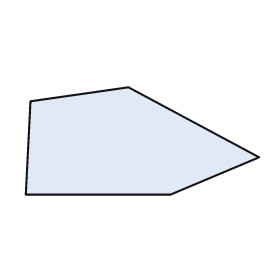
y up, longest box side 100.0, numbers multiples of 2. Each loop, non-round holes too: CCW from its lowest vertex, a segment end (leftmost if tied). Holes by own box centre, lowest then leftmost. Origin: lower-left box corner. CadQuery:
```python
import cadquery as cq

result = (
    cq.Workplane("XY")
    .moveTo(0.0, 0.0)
    .lineTo(62.0, 0.0)
    .lineTo(100.0, 16.0)
    .lineTo(44.0, 46.0)
    .lineTo(2.0, 40.0)
    .close()
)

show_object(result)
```